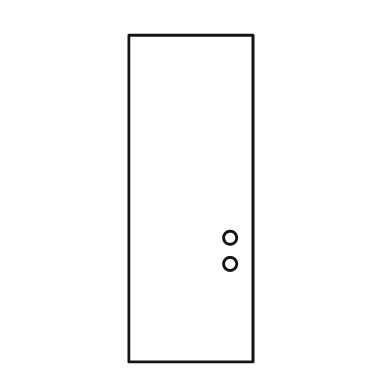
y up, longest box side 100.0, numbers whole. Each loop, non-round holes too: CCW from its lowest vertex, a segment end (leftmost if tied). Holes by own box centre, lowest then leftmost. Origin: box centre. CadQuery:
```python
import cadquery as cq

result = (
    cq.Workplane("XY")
    .moveTo(-19.0, -50.0)
    .lineTo(19.0, -50.0)
    .lineTo(19.0, 50.0)
    .lineTo(-19.0, 50.0)
    .close()
    .moveTo(12.0, -20.0)
    .circle(2.0)
    .moveTo(12.0, -12.0)
    .circle(2.0)
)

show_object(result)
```